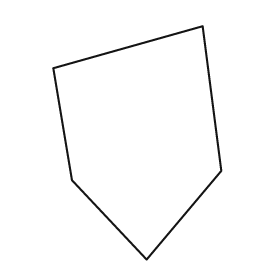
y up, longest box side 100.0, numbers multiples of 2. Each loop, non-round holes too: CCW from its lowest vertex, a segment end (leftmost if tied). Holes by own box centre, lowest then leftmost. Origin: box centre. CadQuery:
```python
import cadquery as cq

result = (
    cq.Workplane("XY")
    .moveTo(4.0, -50.0)
    .lineTo(36.0, -12.0)
    .lineTo(28.0, 50.0)
    .lineTo(-36.0, 32.0)
    .lineTo(-28.0, -16.0)
    .close()
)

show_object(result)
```